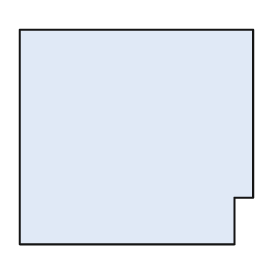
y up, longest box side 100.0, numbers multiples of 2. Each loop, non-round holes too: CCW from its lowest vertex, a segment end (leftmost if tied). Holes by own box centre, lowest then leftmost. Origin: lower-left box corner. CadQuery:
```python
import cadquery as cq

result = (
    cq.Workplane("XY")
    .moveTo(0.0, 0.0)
    .lineTo(92.0, 0.0)
    .lineTo(92.0, 20.0)
    .lineTo(100.0, 20.0)
    .lineTo(100.0, 92.0)
    .lineTo(0.0, 92.0)
    .close()
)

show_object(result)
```